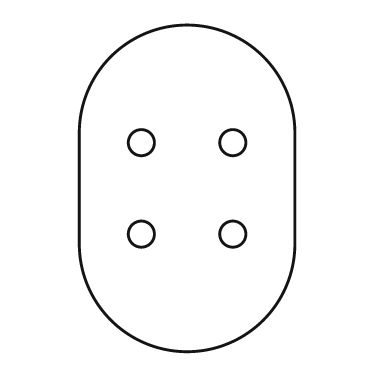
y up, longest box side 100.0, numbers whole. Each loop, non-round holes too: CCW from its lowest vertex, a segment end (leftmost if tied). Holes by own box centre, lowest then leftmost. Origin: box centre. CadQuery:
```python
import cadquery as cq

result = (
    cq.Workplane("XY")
    .moveTo(-33.0, -17.0)
    .threePointArc((0.0, -50.0), (33.0, -17.0))
    .lineTo(33.0, 17.0)
    .threePointArc((0.0, 50.0), (-33.0, 17.0))
    .close()
    .moveTo(-14.0, -14.0)
    .circle(4.0)
    .moveTo(14.0, -14.0)
    .circle(4.0)
    .moveTo(-14.0, 14.0)
    .circle(4.0)
    .moveTo(14.0, 14.0)
    .circle(4.0)
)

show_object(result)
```